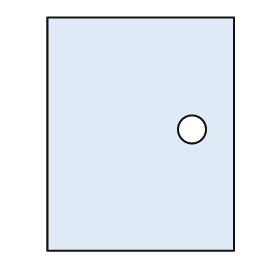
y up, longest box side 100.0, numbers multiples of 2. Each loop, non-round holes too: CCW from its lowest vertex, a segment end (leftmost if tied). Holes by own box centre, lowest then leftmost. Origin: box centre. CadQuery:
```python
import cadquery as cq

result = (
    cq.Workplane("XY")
    .moveTo(-40.0, -50.0)
    .lineTo(40.0, -50.0)
    .lineTo(40.0, 50.0)
    .lineTo(-40.0, 50.0)
    .close()
    .moveTo(22.0, 2.0)
    .circle(6.0)
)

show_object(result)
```